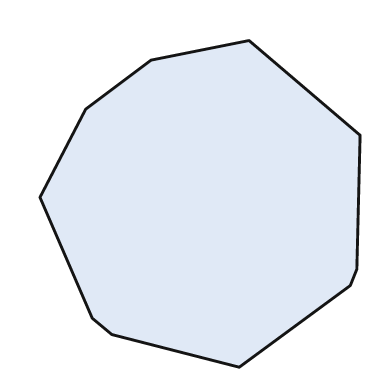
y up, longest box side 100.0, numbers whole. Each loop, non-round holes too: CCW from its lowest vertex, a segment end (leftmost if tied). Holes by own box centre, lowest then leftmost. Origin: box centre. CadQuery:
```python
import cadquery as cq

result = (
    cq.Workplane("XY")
    .moveTo(12.0, -50.0)
    .lineTo(46.0, -25.0)
    .lineTo(48.0, -20.0)
    .lineTo(49.0, 21.0)
    .lineTo(15.0, 50.0)
    .lineTo(-15.0, 44.0)
    .lineTo(-35.0, 29.0)
    .lineTo(-49.0, 2.0)
    .lineTo(-33.0, -35.0)
    .lineTo(-27.0, -40.0)
    .close()
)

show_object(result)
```